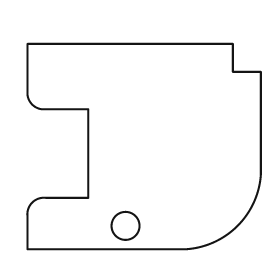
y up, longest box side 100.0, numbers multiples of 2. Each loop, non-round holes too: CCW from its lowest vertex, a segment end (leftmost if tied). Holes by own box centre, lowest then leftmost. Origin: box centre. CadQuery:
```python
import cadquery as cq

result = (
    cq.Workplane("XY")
    .moveTo(-50.0, -44.0)
    .lineTo(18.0, -44.0)
    .threePointArc((40.0, -34.0), (50.0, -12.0))
    .lineTo(50.0, 32.0)
    .lineTo(38.0, 32.0)
    .lineTo(38.0, 44.0)
    .lineTo(-50.0, 44.0)
    .lineTo(-50.0, 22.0)
    .threePointArc((-48.0, 18.0), (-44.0, 16.0))
    .lineTo(-24.0, 16.0)
    .lineTo(-24.0, -22.0)
    .lineTo(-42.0, -22.0)
    .threePointArc((-48.0, -24.0), (-50.0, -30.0))
    .close()
    .moveTo(-8.0, -34.0)
    .circle(6.0)
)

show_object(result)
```